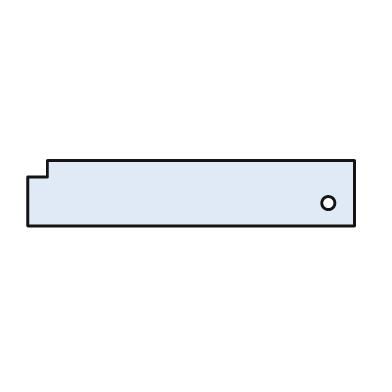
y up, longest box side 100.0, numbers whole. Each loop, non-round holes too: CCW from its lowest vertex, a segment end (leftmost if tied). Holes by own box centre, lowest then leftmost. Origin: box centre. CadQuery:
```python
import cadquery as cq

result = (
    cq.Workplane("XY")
    .moveTo(-50.0, -10.0)
    .lineTo(50.0, -10.0)
    .lineTo(50.0, 10.0)
    .lineTo(-44.0, 10.0)
    .lineTo(-44.0, 5.0)
    .lineTo(-50.0, 5.0)
    .close()
    .moveTo(42.0, -3.0)
    .circle(2.0)
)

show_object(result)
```